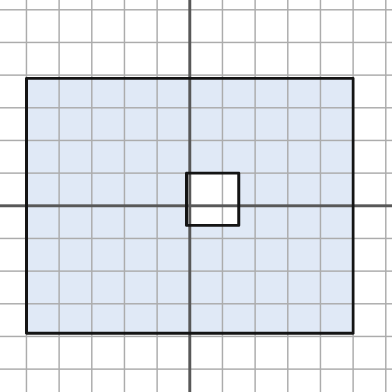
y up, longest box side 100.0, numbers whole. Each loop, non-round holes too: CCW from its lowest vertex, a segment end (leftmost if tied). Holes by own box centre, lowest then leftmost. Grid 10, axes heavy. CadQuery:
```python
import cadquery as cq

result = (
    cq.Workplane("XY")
    .moveTo(-50.0, -39.0)
    .lineTo(50.0, -39.0)
    .lineTo(50.0, 39.0)
    .lineTo(-50.0, 39.0)
    .close()
    .moveTo(-1.0, -6.0)
    .lineTo(15.0, -6.0)
    .lineTo(15.0, 10.0)
    .lineTo(-1.0, 10.0)
    .close()
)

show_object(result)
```